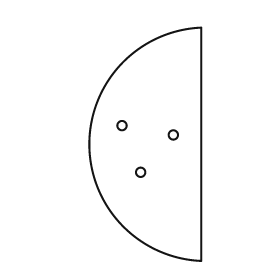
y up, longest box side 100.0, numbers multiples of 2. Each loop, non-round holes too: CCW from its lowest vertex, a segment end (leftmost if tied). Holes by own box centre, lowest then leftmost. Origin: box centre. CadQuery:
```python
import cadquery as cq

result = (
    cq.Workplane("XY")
    .moveTo(24.0, -50.0)
    .lineTo(24.0, 50.0)
    .threePointArc((-24.0, 0.0), (24.0, -50.0))
    .close()
    .moveTo(-2.0, -12.0)
    .circle(2.0)
    .moveTo(12.0, 4.0)
    .circle(2.0)
    .moveTo(-10.0, 8.0)
    .circle(2.0)
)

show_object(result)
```